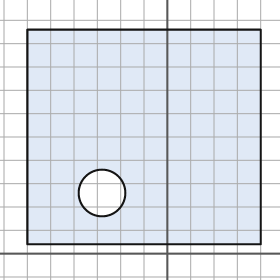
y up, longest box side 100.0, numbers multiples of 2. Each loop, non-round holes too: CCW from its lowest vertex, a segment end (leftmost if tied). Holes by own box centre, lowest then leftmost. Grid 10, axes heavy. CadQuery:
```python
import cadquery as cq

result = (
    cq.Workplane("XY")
    .moveTo(-60.0, 4.0)
    .lineTo(40.0, 4.0)
    .lineTo(40.0, 96.0)
    .lineTo(-60.0, 96.0)
    .close()
    .moveTo(-28.0, 26.0)
    .circle(10.0)
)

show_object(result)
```